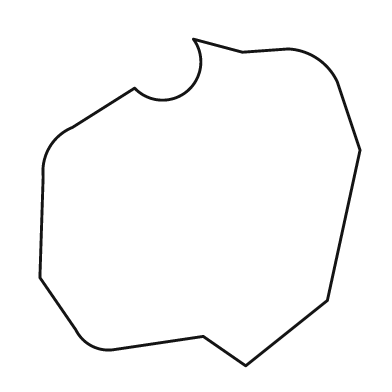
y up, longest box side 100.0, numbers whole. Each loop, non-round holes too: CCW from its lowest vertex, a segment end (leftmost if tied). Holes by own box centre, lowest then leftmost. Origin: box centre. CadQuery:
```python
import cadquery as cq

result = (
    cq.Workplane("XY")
    .moveTo(14.0, -50.0)
    .lineTo(39.0, -30.0)
    .lineTo(49.0, 16.0)
    .lineTo(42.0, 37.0)
    .threePointArc((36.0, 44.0), (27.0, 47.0))
    .lineTo(13.0, 46.0)
    .lineTo(-2.0, 50.0)
    .threePointArc((-4.0, 34.0), (-20.0, 35.0))
    .lineTo(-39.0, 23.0)
    .threePointArc((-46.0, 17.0), (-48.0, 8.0))
    .lineTo(-49.0, -23.0)
    .lineTo(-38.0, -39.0)
    .threePointArc((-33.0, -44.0), (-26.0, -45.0))
    .lineTo(1.0, -41.0)
    .close()
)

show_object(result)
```